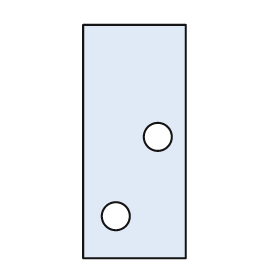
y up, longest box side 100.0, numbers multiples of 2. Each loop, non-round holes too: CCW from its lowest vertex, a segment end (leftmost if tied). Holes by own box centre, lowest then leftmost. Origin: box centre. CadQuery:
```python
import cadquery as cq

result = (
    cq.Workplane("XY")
    .moveTo(-22.0, -50.0)
    .lineTo(22.0, -50.0)
    .lineTo(22.0, 50.0)
    .lineTo(-22.0, 50.0)
    .close()
    .moveTo(-8.0, -32.0)
    .circle(6.0)
    .moveTo(10.0, 2.0)
    .circle(6.0)
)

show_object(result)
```